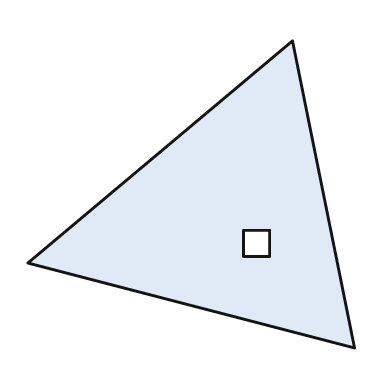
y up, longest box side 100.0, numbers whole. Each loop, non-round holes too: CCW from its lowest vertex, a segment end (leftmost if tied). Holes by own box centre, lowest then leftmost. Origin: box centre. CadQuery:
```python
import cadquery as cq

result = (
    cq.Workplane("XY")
    .moveTo(50.0, -47.0)
    .lineTo(31.0, 47.0)
    .lineTo(-50.0, -21.0)
    .close()
    .moveTo(16.0, -19.0)
    .lineTo(24.0, -19.0)
    .lineTo(24.0, -11.0)
    .lineTo(16.0, -11.0)
    .close()
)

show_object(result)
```